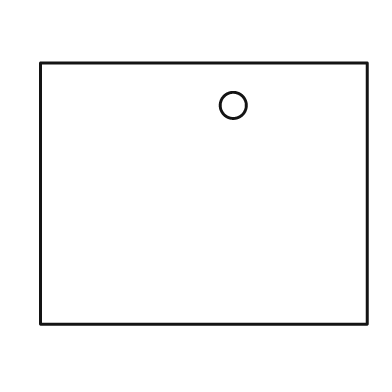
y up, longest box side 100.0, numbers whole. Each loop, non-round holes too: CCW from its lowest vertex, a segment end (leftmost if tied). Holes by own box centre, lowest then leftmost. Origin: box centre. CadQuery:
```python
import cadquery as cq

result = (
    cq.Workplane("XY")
    .moveTo(-50.0, -40.0)
    .lineTo(50.0, -40.0)
    .lineTo(50.0, 40.0)
    .lineTo(-50.0, 40.0)
    .close()
    .moveTo(9.0, 27.0)
    .circle(4.0)
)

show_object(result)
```